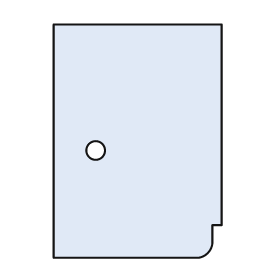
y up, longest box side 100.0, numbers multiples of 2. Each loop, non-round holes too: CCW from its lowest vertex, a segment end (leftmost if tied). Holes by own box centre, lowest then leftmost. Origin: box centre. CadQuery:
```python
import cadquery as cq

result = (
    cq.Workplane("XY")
    .moveTo(-36.0, -50.0)
    .lineTo(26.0, -50.0)
    .threePointArc((30.0, -48.0), (32.0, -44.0))
    .lineTo(32.0, -36.0)
    .lineTo(36.0, -36.0)
    .lineTo(36.0, 50.0)
    .lineTo(-36.0, 50.0)
    .close()
    .moveTo(-18.0, -4.0)
    .circle(4.0)
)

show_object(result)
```